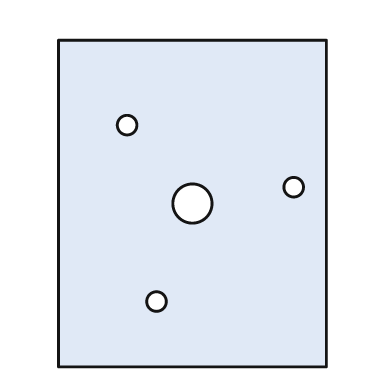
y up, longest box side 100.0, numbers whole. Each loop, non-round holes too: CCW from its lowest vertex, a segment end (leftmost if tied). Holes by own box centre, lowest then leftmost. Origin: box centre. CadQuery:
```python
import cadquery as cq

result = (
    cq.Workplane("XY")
    .moveTo(-41.0, -50.0)
    .lineTo(41.0, -50.0)
    .lineTo(41.0, 50.0)
    .lineTo(-41.0, 50.0)
    .close()
    .moveTo(-11.0, -30.0)
    .circle(3.0)
    .moveTo(0.0, 0.0)
    .circle(6.0)
    .moveTo(31.0, 5.0)
    .circle(3.0)
    .moveTo(-20.0, 24.0)
    .circle(3.0)
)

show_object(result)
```